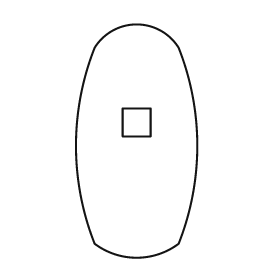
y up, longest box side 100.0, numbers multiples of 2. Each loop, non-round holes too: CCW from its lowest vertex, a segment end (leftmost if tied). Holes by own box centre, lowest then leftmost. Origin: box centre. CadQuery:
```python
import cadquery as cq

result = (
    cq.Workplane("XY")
    .moveTo(-18.0, -44.0)
    .threePointArc((0.0, -50.0), (18.0, -44.0))
    .threePointArc((26.0, -2.0), (18.0, 40.0))
    .threePointArc((0.0, 50.0), (-18.0, 40.0))
    .threePointArc((-26.0, -2.0), (-18.0, -44.0))
    .close()
    .moveTo(-6.0, 2.0)
    .lineTo(6.0, 2.0)
    .lineTo(6.0, 14.0)
    .lineTo(-6.0, 14.0)
    .close()
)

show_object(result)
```